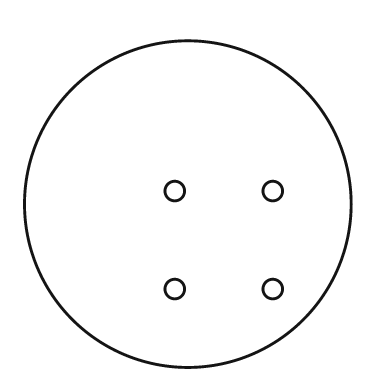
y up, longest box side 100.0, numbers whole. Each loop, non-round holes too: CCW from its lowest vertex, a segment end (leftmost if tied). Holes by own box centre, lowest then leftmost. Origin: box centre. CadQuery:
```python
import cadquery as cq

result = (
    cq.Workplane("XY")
    .moveTo(0.0, 0.0)
    .circle(50.0)
    .moveTo(-4.0, -26.0)
    .circle(3.0)
    .moveTo(26.0, -26.0)
    .circle(3.0)
    .moveTo(-4.0, 4.0)
    .circle(3.0)
    .moveTo(26.0, 4.0)
    .circle(3.0)
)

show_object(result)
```